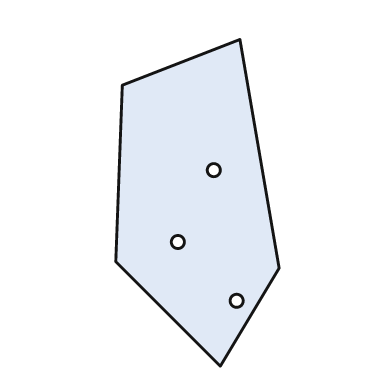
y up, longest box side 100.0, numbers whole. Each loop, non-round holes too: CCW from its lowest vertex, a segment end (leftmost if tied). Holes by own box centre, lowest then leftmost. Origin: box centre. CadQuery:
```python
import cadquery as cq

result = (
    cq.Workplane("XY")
    .moveTo(7.0, -50.0)
    .lineTo(25.0, -20.0)
    .lineTo(13.0, 50.0)
    .lineTo(-23.0, 36.0)
    .lineTo(-25.0, -18.0)
    .close()
    .moveTo(12.0, -30.0)
    .circle(2.0)
    .moveTo(-6.0, -12.0)
    .circle(2.0)
    .moveTo(5.0, 10.0)
    .circle(2.0)
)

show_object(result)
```